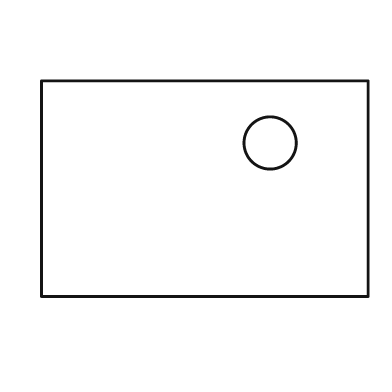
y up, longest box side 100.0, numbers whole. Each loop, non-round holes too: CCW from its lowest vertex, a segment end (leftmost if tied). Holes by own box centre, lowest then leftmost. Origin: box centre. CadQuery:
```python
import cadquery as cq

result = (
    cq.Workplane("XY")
    .moveTo(-50.0, -33.0)
    .lineTo(50.0, -33.0)
    .lineTo(50.0, 33.0)
    .lineTo(-50.0, 33.0)
    .close()
    .moveTo(20.0, 14.0)
    .circle(8.0)
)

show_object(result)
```